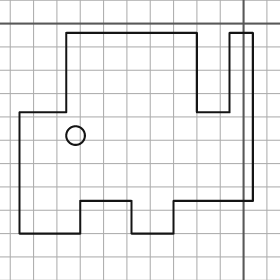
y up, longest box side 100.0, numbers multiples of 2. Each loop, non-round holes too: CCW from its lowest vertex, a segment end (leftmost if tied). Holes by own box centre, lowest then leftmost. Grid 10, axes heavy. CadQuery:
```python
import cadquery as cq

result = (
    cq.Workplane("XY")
    .moveTo(-96.0, -90.0)
    .lineTo(-70.0, -90.0)
    .lineTo(-70.0, -76.0)
    .lineTo(-48.0, -76.0)
    .lineTo(-48.0, -90.0)
    .lineTo(-30.0, -90.0)
    .lineTo(-30.0, -76.0)
    .lineTo(4.0, -76.0)
    .lineTo(4.0, -4.0)
    .lineTo(-6.0, -4.0)
    .lineTo(-6.0, -38.0)
    .lineTo(-20.0, -38.0)
    .lineTo(-20.0, -4.0)
    .lineTo(-76.0, -4.0)
    .lineTo(-76.0, -38.0)
    .lineTo(-96.0, -38.0)
    .close()
    .moveTo(-72.0, -48.0)
    .circle(4.0)
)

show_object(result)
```